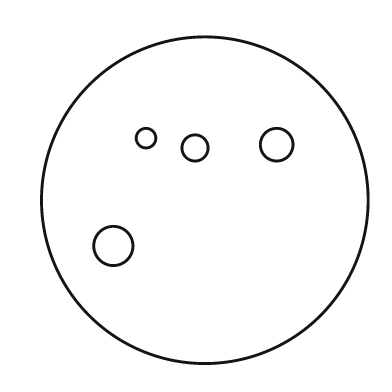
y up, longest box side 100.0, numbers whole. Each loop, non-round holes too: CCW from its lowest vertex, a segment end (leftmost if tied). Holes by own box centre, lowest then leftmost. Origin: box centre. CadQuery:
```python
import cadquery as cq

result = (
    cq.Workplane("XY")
    .moveTo(0.0, 0.0)
    .circle(50.0)
    .moveTo(-28.0, -14.0)
    .circle(6.0)
    .moveTo(-3.0, 16.0)
    .circle(4.0)
    .moveTo(22.0, 17.0)
    .circle(5.0)
    .moveTo(-18.0, 19.0)
    .circle(3.0)
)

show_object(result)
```